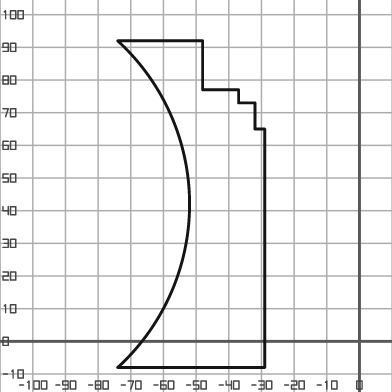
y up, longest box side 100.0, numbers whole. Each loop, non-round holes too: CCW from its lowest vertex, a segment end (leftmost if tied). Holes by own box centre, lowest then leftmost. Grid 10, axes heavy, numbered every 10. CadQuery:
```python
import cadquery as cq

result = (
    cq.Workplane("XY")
    .moveTo(-74.0, -8.0)
    .lineTo(-29.0, -8.0)
    .lineTo(-29.0, 65.0)
    .lineTo(-32.0, 65.0)
    .lineTo(-32.0, 73.0)
    .lineTo(-37.0, 73.0)
    .lineTo(-37.0, 77.0)
    .lineTo(-48.0, 77.0)
    .lineTo(-48.0, 92.0)
    .lineTo(-74.0, 92.0)
    .threePointArc((-52.0, 42.0), (-74.0, -8.0))
    .close()
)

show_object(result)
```